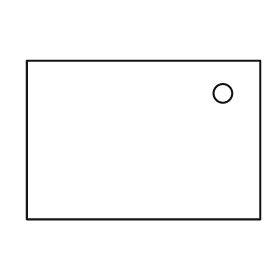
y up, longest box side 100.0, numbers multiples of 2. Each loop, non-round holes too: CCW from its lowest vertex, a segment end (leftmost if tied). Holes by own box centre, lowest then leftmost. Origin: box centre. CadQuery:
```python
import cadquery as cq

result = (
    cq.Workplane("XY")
    .moveTo(-50.0, -34.0)
    .lineTo(50.0, -34.0)
    .lineTo(50.0, 34.0)
    .lineTo(-50.0, 34.0)
    .close()
    .moveTo(34.0, 20.0)
    .circle(4.0)
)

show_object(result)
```